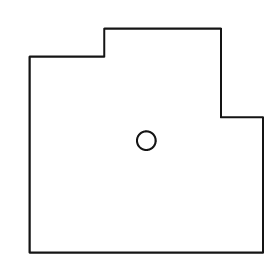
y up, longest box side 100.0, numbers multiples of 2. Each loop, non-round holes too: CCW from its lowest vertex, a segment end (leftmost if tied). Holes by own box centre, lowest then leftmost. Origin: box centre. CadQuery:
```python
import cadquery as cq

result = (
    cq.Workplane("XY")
    .moveTo(-50.0, -48.0)
    .lineTo(50.0, -48.0)
    .lineTo(50.0, 10.0)
    .lineTo(32.0, 10.0)
    .lineTo(32.0, 48.0)
    .lineTo(-18.0, 48.0)
    .lineTo(-18.0, 36.0)
    .lineTo(-50.0, 36.0)
    .close()
    .moveTo(0.0, 0.0)
    .circle(4.0)
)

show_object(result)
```